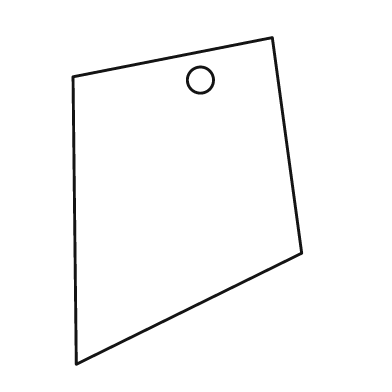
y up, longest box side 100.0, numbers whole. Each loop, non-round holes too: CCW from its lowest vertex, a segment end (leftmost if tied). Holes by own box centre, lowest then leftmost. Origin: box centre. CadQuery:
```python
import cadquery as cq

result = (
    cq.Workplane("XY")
    .moveTo(-34.0, -50.0)
    .lineTo(35.0, -16.0)
    .lineTo(26.0, 50.0)
    .lineTo(-35.0, 38.0)
    .close()
    .moveTo(4.0, 37.0)
    .circle(4.0)
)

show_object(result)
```